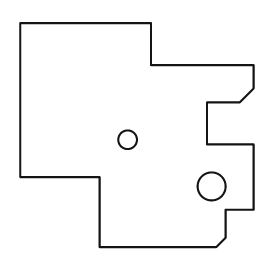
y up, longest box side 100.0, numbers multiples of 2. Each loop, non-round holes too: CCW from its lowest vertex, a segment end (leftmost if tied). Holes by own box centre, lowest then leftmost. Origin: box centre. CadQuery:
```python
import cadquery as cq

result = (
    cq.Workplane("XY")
    .moveTo(-16.0, -48.0)
    .lineTo(34.0, -48.0)
    .lineTo(38.0, -44.0)
    .lineTo(38.0, -32.0)
    .lineTo(50.0, -32.0)
    .lineTo(50.0, -4.0)
    .lineTo(30.0, -4.0)
    .lineTo(30.0, 14.0)
    .lineTo(44.0, 14.0)
    .lineTo(50.0, 20.0)
    .lineTo(50.0, 30.0)
    .lineTo(6.0, 30.0)
    .lineTo(6.0, 48.0)
    .lineTo(-50.0, 48.0)
    .lineTo(-50.0, -18.0)
    .lineTo(-16.0, -18.0)
    .close()
    .moveTo(32.0, -22.0)
    .circle(6.0)
    .moveTo(-4.0, -2.0)
    .circle(4.0)
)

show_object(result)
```